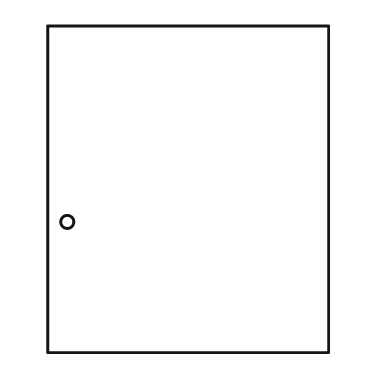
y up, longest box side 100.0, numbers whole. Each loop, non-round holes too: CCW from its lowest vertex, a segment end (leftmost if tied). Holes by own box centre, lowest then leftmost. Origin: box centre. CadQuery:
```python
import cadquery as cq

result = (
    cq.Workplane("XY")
    .moveTo(-43.0, -50.0)
    .lineTo(43.0, -50.0)
    .lineTo(43.0, 50.0)
    .lineTo(-43.0, 50.0)
    .close()
    .moveTo(-37.0, -10.0)
    .circle(2.0)
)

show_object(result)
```